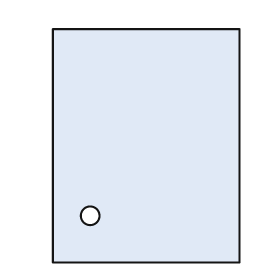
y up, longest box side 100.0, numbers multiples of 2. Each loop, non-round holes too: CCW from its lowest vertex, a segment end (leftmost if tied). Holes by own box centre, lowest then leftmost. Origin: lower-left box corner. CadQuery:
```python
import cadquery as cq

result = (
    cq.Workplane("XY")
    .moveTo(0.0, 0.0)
    .lineTo(80.0, 0.0)
    .lineTo(80.0, 100.0)
    .lineTo(0.0, 100.0)
    .close()
    .moveTo(16.0, 20.0)
    .circle(4.0)
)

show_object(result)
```